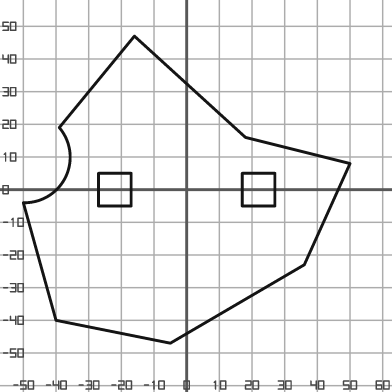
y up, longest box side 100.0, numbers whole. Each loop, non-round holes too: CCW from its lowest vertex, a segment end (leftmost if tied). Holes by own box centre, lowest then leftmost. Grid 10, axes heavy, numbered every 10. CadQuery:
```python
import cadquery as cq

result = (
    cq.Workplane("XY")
    .moveTo(-5.0, -47.0)
    .lineTo(36.0, -23.0)
    .lineTo(50.0, 8.0)
    .lineTo(18.0, 16.0)
    .lineTo(-16.0, 47.0)
    .lineTo(-39.0, 19.0)
    .threePointArc((-37.0, 4.0), (-50.0, -4.0))
    .lineTo(-40.0, -40.0)
    .close()
    .moveTo(-27.0, -5.0)
    .lineTo(-17.0, -5.0)
    .lineTo(-17.0, 5.0)
    .lineTo(-27.0, 5.0)
    .close()
    .moveTo(17.0, -5.0)
    .lineTo(27.0, -5.0)
    .lineTo(27.0, 5.0)
    .lineTo(17.0, 5.0)
    .close()
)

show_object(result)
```